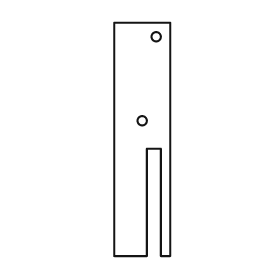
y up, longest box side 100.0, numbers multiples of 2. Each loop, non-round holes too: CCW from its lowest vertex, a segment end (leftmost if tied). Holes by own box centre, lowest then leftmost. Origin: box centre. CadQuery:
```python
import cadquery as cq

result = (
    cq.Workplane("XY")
    .moveTo(-12.0, -50.0)
    .lineTo(2.0, -50.0)
    .lineTo(2.0, -4.0)
    .lineTo(8.0, -4.0)
    .lineTo(8.0, -50.0)
    .lineTo(12.0, -50.0)
    .lineTo(12.0, 50.0)
    .lineTo(-12.0, 50.0)
    .close()
    .moveTo(0.0, 8.0)
    .circle(2.0)
    .moveTo(6.0, 44.0)
    .circle(2.0)
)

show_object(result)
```